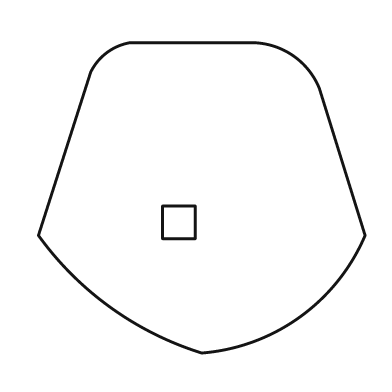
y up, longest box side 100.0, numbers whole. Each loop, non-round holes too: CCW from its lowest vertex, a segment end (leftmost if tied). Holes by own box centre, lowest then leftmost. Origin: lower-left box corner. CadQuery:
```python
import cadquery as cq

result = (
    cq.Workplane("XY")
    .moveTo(50.0, 0.0)
    .threePointArc((80.0, 11.0), (100.0, 36.0))
    .lineTo(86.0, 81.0)
    .threePointArc((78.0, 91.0), (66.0, 95.0))
    .lineTo(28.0, 95.0)
    .threePointArc((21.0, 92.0), (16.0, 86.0))
    .lineTo(0.0, 36.0)
    .threePointArc((22.0, 14.0), (50.0, 0.0))
    .close()
    .moveTo(38.0, 35.0)
    .lineTo(48.0, 35.0)
    .lineTo(48.0, 45.0)
    .lineTo(38.0, 45.0)
    .close()
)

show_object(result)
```